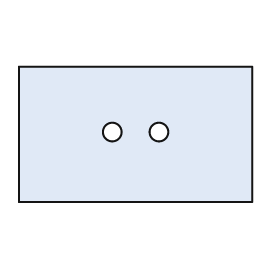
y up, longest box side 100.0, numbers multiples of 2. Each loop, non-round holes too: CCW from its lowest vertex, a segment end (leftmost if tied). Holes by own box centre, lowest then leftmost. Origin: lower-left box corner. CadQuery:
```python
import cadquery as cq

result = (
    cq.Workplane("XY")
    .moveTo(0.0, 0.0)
    .lineTo(100.0, 0.0)
    .lineTo(100.0, 58.0)
    .lineTo(0.0, 58.0)
    .close()
    .moveTo(40.0, 30.0)
    .circle(4.0)
    .moveTo(60.0, 30.0)
    .circle(4.0)
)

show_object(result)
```